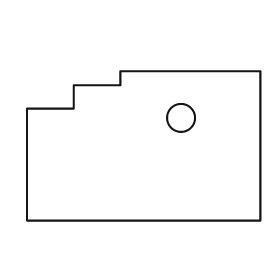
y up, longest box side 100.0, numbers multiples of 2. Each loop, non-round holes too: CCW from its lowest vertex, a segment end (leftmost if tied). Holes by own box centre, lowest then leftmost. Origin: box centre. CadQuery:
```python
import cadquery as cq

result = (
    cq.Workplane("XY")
    .moveTo(-50.0, -32.0)
    .lineTo(50.0, -32.0)
    .lineTo(50.0, 32.0)
    .lineTo(-10.0, 32.0)
    .lineTo(-10.0, 26.0)
    .lineTo(-30.0, 26.0)
    .lineTo(-30.0, 16.0)
    .lineTo(-50.0, 16.0)
    .close()
    .moveTo(16.0, 12.0)
    .circle(6.0)
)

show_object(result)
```